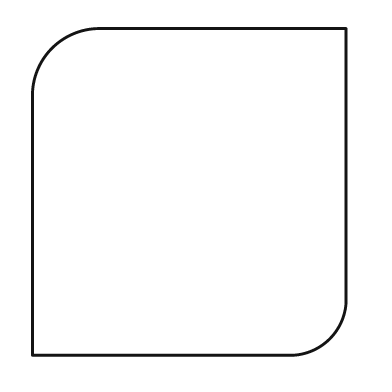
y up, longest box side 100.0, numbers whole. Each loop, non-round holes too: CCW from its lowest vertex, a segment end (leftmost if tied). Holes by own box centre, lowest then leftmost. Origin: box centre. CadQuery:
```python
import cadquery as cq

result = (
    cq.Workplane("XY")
    .moveTo(-48.0, -50.0)
    .lineTo(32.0, -50.0)
    .threePointArc((43.0, -45.0), (48.0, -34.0))
    .lineTo(48.0, 50.0)
    .lineTo(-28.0, 50.0)
    .threePointArc((-42.0, 44.0), (-48.0, 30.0))
    .close()
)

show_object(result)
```